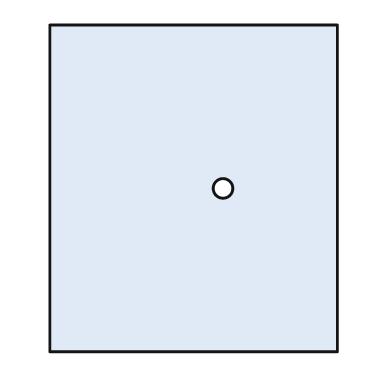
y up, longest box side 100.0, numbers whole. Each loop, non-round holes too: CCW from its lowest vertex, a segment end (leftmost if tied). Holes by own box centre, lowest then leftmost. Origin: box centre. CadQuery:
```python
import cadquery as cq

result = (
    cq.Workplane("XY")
    .moveTo(-44.0, -50.0)
    .lineTo(44.0, -50.0)
    .lineTo(44.0, 50.0)
    .lineTo(-44.0, 50.0)
    .close()
    .moveTo(9.0, 0.0)
    .circle(3.0)
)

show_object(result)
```